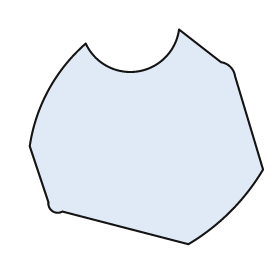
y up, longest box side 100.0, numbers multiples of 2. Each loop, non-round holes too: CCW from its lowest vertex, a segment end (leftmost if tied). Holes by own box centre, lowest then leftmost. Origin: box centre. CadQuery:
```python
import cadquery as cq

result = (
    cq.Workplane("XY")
    .moveTo(18.0, -46.0)
    .threePointArc((36.0, -32.0), (50.0, -14.0))
    .lineTo(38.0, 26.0)
    .threePointArc((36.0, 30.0), (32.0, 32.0))
    .lineTo(14.0, 46.0)
    .threePointArc((-4.0, 28.0), (-26.0, 40.0))
    .threePointArc((-42.0, 20.0), (-50.0, -4.0))
    .lineTo(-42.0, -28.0)
    .threePointArc((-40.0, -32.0), (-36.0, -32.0))
    .close()
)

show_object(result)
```